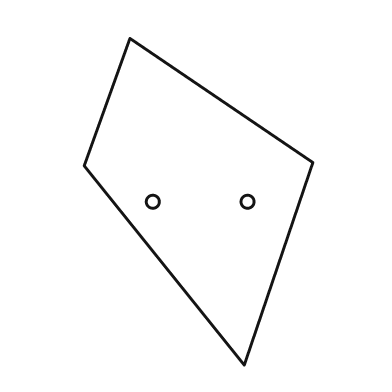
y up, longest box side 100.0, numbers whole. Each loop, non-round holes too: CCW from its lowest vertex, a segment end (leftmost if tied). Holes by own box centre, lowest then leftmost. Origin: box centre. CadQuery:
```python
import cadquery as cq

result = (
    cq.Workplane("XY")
    .moveTo(14.0, -50.0)
    .lineTo(35.0, 12.0)
    .lineTo(-21.0, 50.0)
    .lineTo(-35.0, 11.0)
    .close()
    .moveTo(-14.0, 0.0)
    .circle(2.0)
    .moveTo(15.0, 0.0)
    .circle(2.0)
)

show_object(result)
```